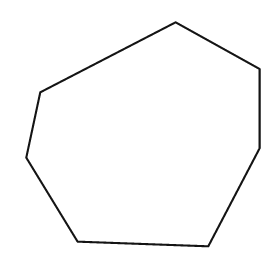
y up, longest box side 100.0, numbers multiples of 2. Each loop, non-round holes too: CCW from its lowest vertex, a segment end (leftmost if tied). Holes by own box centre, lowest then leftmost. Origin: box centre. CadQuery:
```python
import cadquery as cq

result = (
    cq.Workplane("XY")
    .moveTo(28.0, -48.0)
    .lineTo(50.0, -6.0)
    .lineTo(50.0, 28.0)
    .lineTo(14.0, 48.0)
    .lineTo(-44.0, 18.0)
    .lineTo(-50.0, -10.0)
    .lineTo(-28.0, -46.0)
    .close()
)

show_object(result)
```